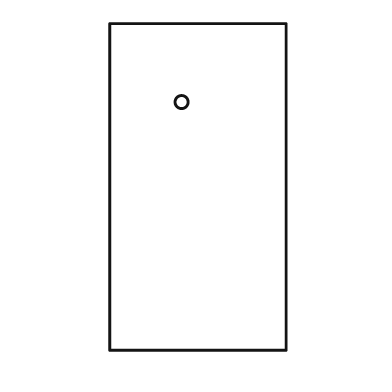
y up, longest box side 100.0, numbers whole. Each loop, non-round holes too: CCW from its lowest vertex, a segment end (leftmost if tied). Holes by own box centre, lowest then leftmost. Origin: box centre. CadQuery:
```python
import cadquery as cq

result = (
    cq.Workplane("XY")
    .moveTo(-27.0, -50.0)
    .lineTo(27.0, -50.0)
    .lineTo(27.0, 50.0)
    .lineTo(-27.0, 50.0)
    .close()
    .moveTo(-5.0, 26.0)
    .circle(2.0)
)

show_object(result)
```